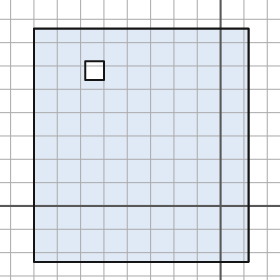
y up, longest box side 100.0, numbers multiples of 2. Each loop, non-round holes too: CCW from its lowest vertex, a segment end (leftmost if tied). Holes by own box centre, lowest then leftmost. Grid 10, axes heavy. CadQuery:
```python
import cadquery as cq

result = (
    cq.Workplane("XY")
    .moveTo(-80.0, -24.0)
    .lineTo(12.0, -24.0)
    .lineTo(12.0, 76.0)
    .lineTo(-80.0, 76.0)
    .close()
    .moveTo(-58.0, 54.0)
    .lineTo(-50.0, 54.0)
    .lineTo(-50.0, 62.0)
    .lineTo(-58.0, 62.0)
    .close()
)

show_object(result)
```